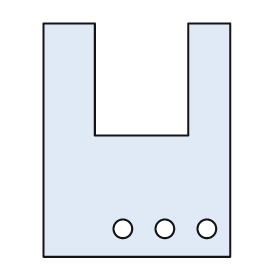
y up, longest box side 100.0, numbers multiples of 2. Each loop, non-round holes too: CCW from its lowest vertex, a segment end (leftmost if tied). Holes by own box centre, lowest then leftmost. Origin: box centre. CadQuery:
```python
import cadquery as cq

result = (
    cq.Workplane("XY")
    .moveTo(-40.0, -50.0)
    .lineTo(40.0, -50.0)
    .lineTo(40.0, 50.0)
    .lineTo(22.0, 50.0)
    .lineTo(22.0, 2.0)
    .lineTo(-18.0, 2.0)
    .lineTo(-18.0, 50.0)
    .lineTo(-40.0, 50.0)
    .close()
    .moveTo(-6.0, -38.0)
    .circle(4.0)
    .moveTo(12.0, -38.0)
    .circle(4.0)
    .moveTo(30.0, -38.0)
    .circle(4.0)
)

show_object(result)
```